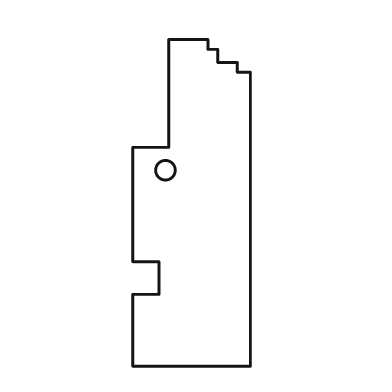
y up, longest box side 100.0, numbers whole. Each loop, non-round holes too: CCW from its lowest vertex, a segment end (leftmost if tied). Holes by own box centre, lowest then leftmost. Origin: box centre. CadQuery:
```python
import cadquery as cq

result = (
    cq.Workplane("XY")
    .moveTo(-18.0, -50.0)
    .lineTo(18.0, -50.0)
    .lineTo(18.0, 40.0)
    .lineTo(14.0, 40.0)
    .lineTo(14.0, 43.0)
    .lineTo(8.0, 43.0)
    .lineTo(8.0, 47.0)
    .lineTo(5.0, 47.0)
    .lineTo(5.0, 50.0)
    .lineTo(-7.0, 50.0)
    .lineTo(-7.0, 17.0)
    .lineTo(-18.0, 17.0)
    .lineTo(-18.0, -18.0)
    .lineTo(-10.0, -18.0)
    .lineTo(-10.0, -28.0)
    .lineTo(-18.0, -28.0)
    .close()
    .moveTo(-8.0, 10.0)
    .circle(3.0)
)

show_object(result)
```